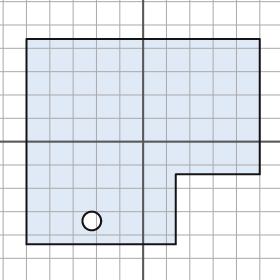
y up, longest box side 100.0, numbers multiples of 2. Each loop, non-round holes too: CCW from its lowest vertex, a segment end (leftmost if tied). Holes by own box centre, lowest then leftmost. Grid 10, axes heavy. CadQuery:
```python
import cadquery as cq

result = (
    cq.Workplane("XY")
    .moveTo(-50.0, -44.0)
    .lineTo(14.0, -44.0)
    .lineTo(14.0, -14.0)
    .lineTo(50.0, -14.0)
    .lineTo(50.0, 44.0)
    .lineTo(-50.0, 44.0)
    .close()
    .moveTo(-22.0, -34.0)
    .circle(4.0)
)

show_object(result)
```